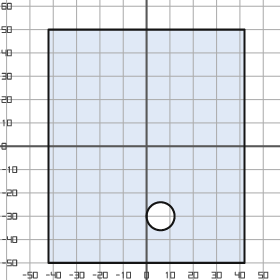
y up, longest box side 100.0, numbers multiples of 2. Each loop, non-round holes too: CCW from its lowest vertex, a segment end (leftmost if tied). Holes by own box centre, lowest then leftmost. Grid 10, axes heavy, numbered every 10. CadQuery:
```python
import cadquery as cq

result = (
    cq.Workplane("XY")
    .moveTo(-42.0, -50.0)
    .lineTo(42.0, -50.0)
    .lineTo(42.0, 50.0)
    .lineTo(-42.0, 50.0)
    .close()
    .moveTo(6.0, -30.0)
    .circle(6.0)
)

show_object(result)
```